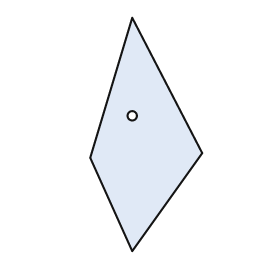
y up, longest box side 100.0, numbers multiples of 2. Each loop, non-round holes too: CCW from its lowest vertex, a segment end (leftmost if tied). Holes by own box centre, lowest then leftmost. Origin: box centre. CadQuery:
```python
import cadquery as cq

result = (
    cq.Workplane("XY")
    .moveTo(-6.0, -50.0)
    .lineTo(24.0, -8.0)
    .lineTo(-6.0, 50.0)
    .lineTo(-24.0, -10.0)
    .close()
    .moveTo(-6.0, 8.0)
    .circle(2.0)
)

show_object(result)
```